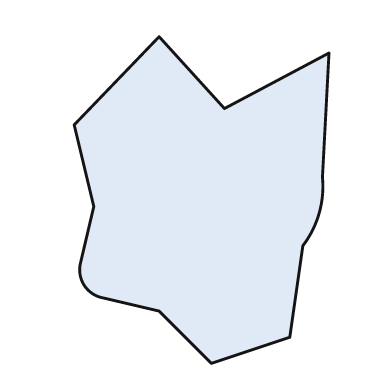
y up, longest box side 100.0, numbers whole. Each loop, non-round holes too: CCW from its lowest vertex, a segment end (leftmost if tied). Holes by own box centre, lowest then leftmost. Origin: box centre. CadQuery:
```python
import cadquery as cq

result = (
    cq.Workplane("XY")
    .moveTo(3.0, -50.0)
    .lineTo(27.0, -42.0)
    .lineTo(31.0, -14.0)
    .threePointArc((36.0, -4.0), (37.0, 7.0))
    .lineTo(39.0, 45.0)
    .lineTo(7.0, 28.0)
    .lineTo(-13.0, 50.0)
    .lineTo(-39.0, 23.0)
    .lineTo(-33.0, -2.0)
    .lineTo(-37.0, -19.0)
    .threePointArc((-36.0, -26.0), (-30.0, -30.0))
    .lineTo(-13.0, -34.0)
    .close()
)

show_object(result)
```